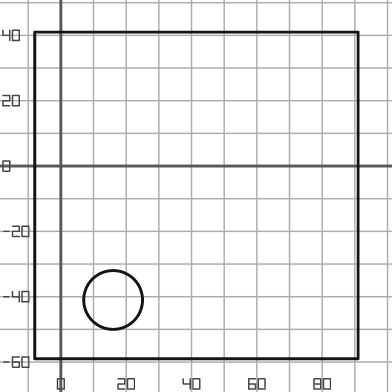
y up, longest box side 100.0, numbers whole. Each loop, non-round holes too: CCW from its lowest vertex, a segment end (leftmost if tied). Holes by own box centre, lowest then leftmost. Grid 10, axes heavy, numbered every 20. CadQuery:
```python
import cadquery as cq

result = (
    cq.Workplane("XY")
    .moveTo(-8.0, -59.0)
    .lineTo(91.0, -59.0)
    .lineTo(91.0, 41.0)
    .lineTo(-8.0, 41.0)
    .close()
    .moveTo(16.0, -41.0)
    .circle(9.0)
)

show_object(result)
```